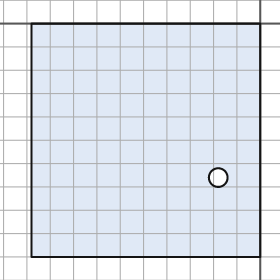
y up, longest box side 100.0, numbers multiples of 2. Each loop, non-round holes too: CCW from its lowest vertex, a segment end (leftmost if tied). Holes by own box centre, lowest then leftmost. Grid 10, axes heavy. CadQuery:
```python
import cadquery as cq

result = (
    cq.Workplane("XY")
    .moveTo(-98.0, -100.0)
    .lineTo(0.0, -100.0)
    .lineTo(0.0, 0.0)
    .lineTo(-98.0, 0.0)
    .close()
    .moveTo(-18.0, -66.0)
    .circle(4.0)
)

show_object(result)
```